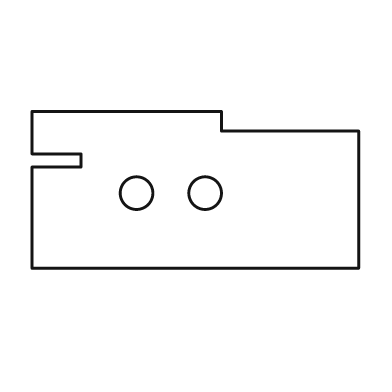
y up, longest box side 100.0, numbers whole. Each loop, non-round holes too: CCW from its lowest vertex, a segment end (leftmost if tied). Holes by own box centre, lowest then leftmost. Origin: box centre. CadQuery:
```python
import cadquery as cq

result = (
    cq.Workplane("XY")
    .moveTo(-50.0, -24.0)
    .lineTo(50.0, -24.0)
    .lineTo(50.0, 18.0)
    .lineTo(8.0, 18.0)
    .lineTo(8.0, 24.0)
    .lineTo(-50.0, 24.0)
    .lineTo(-50.0, 11.0)
    .lineTo(-35.0, 11.0)
    .lineTo(-35.0, 7.0)
    .lineTo(-50.0, 7.0)
    .close()
    .moveTo(-18.0, -1.0)
    .circle(5.0)
    .moveTo(3.0, -1.0)
    .circle(5.0)
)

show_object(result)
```